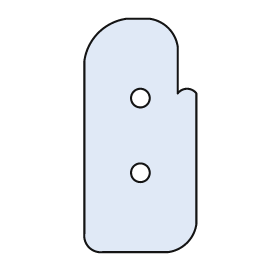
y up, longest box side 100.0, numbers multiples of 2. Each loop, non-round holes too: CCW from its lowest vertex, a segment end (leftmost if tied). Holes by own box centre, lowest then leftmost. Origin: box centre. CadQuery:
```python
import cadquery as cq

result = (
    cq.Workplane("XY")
    .moveTo(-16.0, -50.0)
    .lineTo(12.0, -50.0)
    .threePointArc((20.0, -46.0), (24.0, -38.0))
    .lineTo(24.0, 18.0)
    .threePointArc((20.0, 20.0), (16.0, 18.0))
    .lineTo(16.0, 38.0)
    .threePointArc((12.0, 46.0), (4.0, 50.0))
    .lineTo(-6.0, 50.0)
    .threePointArc((-18.0, 44.0), (-24.0, 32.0))
    .lineTo(-24.0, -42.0)
    .threePointArc((-22.0, -48.0), (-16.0, -50.0))
    .close()
    .moveTo(0.0, -16.0)
    .circle(4.0)
    .moveTo(0.0, 16.0)
    .circle(4.0)
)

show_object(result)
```